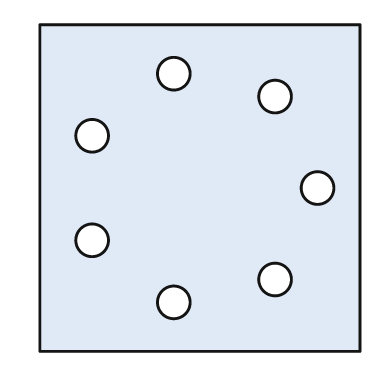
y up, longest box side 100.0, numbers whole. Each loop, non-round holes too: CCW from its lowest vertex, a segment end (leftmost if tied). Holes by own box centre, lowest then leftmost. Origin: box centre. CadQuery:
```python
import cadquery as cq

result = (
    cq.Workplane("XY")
    .moveTo(-49.0, -50.0)
    .lineTo(49.0, -50.0)
    .lineTo(49.0, 50.0)
    .lineTo(-49.0, 50.0)
    .close()
    .moveTo(-8.0, -35.0)
    .circle(5.0)
    .moveTo(23.0, -28.0)
    .circle(5.0)
    .moveTo(-33.0, -16.0)
    .circle(5.0)
    .moveTo(36.0, 0.0)
    .circle(5.0)
    .moveTo(-33.0, 16.0)
    .circle(5.0)
    .moveTo(23.0, 28.0)
    .circle(5.0)
    .moveTo(-8.0, 35.0)
    .circle(5.0)
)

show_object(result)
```